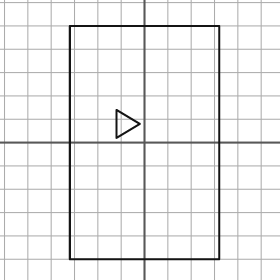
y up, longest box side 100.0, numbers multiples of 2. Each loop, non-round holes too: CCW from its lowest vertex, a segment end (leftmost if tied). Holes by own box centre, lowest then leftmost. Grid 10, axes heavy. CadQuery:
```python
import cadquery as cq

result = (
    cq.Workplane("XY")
    .moveTo(-32.0, -50.0)
    .lineTo(32.0, -50.0)
    .lineTo(32.0, 50.0)
    .lineTo(-32.0, 50.0)
    .close()
    .moveTo(-12.0, 2.0)
    .lineTo(-2.0, 8.0)
    .lineTo(-12.0, 14.0)
    .close()
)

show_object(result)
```